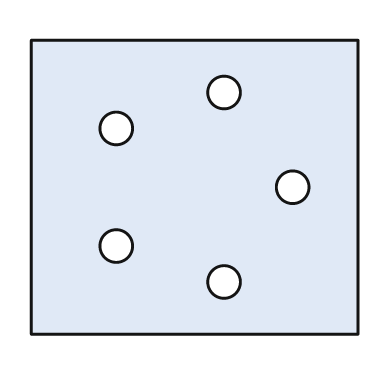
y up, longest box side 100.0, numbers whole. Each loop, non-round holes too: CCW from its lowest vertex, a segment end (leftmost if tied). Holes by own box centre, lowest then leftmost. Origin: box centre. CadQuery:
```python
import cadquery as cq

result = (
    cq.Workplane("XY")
    .moveTo(-50.0, -45.0)
    .lineTo(50.0, -45.0)
    .lineTo(50.0, 45.0)
    .lineTo(-50.0, 45.0)
    .close()
    .moveTo(9.0, -29.0)
    .circle(5.0)
    .moveTo(-24.0, -18.0)
    .circle(5.0)
    .moveTo(30.0, 0.0)
    .circle(5.0)
    .moveTo(-24.0, 18.0)
    .circle(5.0)
    .moveTo(9.0, 29.0)
    .circle(5.0)
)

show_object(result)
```